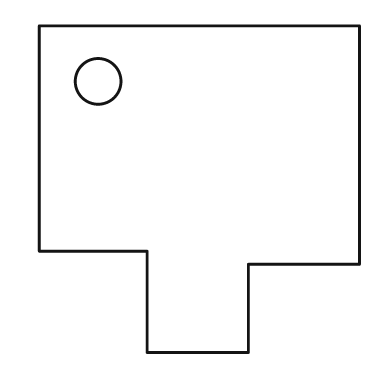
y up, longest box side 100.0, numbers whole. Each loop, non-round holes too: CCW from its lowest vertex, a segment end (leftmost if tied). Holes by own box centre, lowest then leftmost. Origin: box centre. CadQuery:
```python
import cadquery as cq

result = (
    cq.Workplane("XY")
    .moveTo(-16.0, -50.0)
    .lineTo(15.0, -50.0)
    .lineTo(15.0, -23.0)
    .lineTo(49.0, -23.0)
    .lineTo(49.0, 50.0)
    .lineTo(-49.0, 50.0)
    .lineTo(-49.0, -19.0)
    .lineTo(-16.0, -19.0)
    .close()
    .moveTo(-31.0, 33.0)
    .circle(7.0)
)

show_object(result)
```